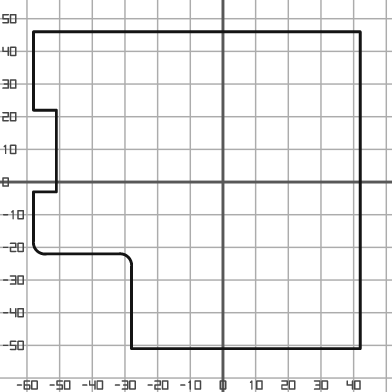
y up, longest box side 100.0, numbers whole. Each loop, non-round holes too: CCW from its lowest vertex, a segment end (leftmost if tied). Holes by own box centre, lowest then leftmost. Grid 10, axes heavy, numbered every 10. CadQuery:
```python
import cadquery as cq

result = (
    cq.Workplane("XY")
    .moveTo(-28.0, -51.0)
    .lineTo(42.0, -51.0)
    .lineTo(42.0, 46.0)
    .lineTo(-58.0, 46.0)
    .lineTo(-58.0, 22.0)
    .lineTo(-51.0, 22.0)
    .lineTo(-51.0, -3.0)
    .lineTo(-58.0, -3.0)
    .lineTo(-58.0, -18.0)
    .threePointArc((-57.0, -21.0), (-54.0, -22.0))
    .lineTo(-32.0, -22.0)
    .threePointArc((-29.0, -23.0), (-28.0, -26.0))
    .close()
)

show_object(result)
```